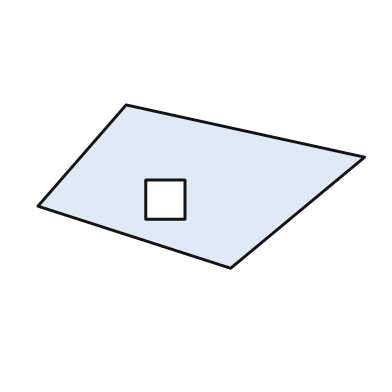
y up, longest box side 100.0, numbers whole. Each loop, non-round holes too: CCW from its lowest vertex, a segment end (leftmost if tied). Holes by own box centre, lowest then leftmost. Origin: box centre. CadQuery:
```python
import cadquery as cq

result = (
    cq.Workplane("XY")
    .moveTo(9.0, -25.0)
    .lineTo(50.0, 9.0)
    .lineTo(-23.0, 25.0)
    .lineTo(-50.0, -6.0)
    .close()
    .moveTo(-17.0, -10.0)
    .lineTo(-5.0, -10.0)
    .lineTo(-5.0, 2.0)
    .lineTo(-17.0, 2.0)
    .close()
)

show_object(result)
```